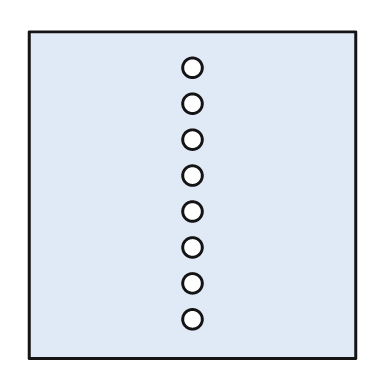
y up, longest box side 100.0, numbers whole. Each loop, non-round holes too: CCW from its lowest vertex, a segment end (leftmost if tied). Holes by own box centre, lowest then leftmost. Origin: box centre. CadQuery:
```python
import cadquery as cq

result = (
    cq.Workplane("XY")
    .moveTo(-50.0, -50.0)
    .lineTo(50.0, -50.0)
    .lineTo(50.0, 50.0)
    .lineTo(-50.0, 50.0)
    .close()
    .moveTo(0.0, -38.0)
    .circle(3.0)
    .moveTo(0.0, -27.0)
    .circle(3.0)
    .moveTo(0.0, -16.0)
    .circle(3.0)
    .moveTo(0.0, -5.0)
    .circle(3.0)
    .moveTo(0.0, 6.0)
    .circle(3.0)
    .moveTo(0.0, 17.0)
    .circle(3.0)
    .moveTo(0.0, 28.0)
    .circle(3.0)
    .moveTo(0.0, 39.0)
    .circle(3.0)
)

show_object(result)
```